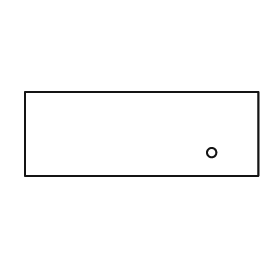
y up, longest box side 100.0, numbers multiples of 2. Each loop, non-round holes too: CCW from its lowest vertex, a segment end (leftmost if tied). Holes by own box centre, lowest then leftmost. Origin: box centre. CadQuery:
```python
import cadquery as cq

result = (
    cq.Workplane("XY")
    .moveTo(-50.0, -18.0)
    .lineTo(50.0, -18.0)
    .lineTo(50.0, 18.0)
    .lineTo(-50.0, 18.0)
    .close()
    .moveTo(30.0, -8.0)
    .circle(2.0)
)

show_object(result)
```